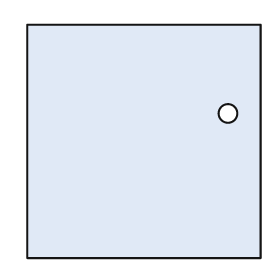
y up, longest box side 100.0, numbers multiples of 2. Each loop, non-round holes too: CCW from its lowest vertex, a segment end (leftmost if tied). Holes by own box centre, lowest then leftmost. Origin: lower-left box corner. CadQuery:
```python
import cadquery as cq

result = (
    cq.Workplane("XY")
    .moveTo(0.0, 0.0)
    .lineTo(100.0, 0.0)
    .lineTo(100.0, 100.0)
    .lineTo(0.0, 100.0)
    .close()
    .moveTo(86.0, 62.0)
    .circle(4.0)
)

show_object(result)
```